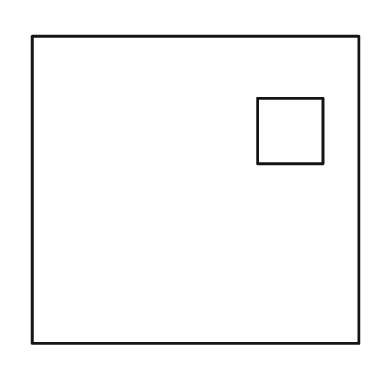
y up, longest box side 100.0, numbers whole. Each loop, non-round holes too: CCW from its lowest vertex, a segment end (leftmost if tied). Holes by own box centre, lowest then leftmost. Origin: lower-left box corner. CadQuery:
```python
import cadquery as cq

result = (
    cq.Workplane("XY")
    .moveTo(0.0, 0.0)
    .lineTo(100.0, 0.0)
    .lineTo(100.0, 94.0)
    .lineTo(0.0, 94.0)
    .close()
    .moveTo(69.0, 55.0)
    .lineTo(89.0, 55.0)
    .lineTo(89.0, 75.0)
    .lineTo(69.0, 75.0)
    .close()
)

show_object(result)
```